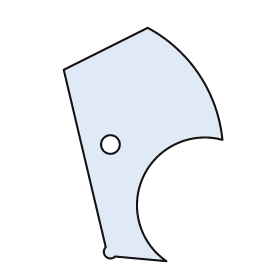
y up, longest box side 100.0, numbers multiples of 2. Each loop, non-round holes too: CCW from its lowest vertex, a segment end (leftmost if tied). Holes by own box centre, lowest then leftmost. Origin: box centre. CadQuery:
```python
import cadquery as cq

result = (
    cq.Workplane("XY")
    .moveTo(10.0, -50.0)
    .threePointArc((0.0, -14.0), (34.0, 2.0))
    .threePointArc((24.0, 30.0), (2.0, 50.0))
    .lineTo(-34.0, 32.0)
    .lineTo(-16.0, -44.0)
    .threePointArc((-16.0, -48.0), (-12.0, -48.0))
    .close()
    .moveTo(-14.0, 0.0)
    .circle(4.0)
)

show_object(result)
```